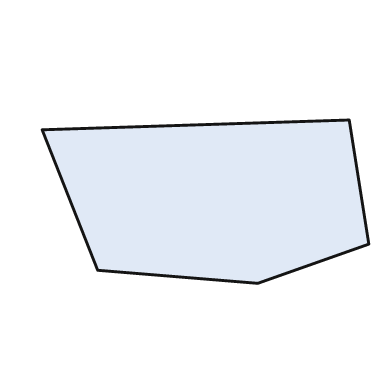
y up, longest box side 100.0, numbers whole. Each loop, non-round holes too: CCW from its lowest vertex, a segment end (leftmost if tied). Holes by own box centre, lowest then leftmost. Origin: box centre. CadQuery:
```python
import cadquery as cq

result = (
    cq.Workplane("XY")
    .moveTo(16.0, -25.0)
    .lineTo(50.0, -13.0)
    .lineTo(44.0, 25.0)
    .lineTo(-50.0, 22.0)
    .lineTo(-33.0, -21.0)
    .close()
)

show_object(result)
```